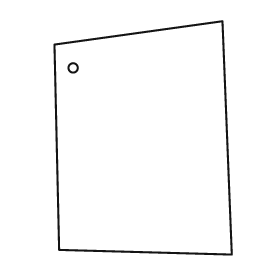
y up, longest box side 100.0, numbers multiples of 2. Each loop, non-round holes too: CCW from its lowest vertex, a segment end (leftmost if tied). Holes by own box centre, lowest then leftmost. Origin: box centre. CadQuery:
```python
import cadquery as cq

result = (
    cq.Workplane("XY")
    .moveTo(38.0, -50.0)
    .lineTo(34.0, 50.0)
    .lineTo(-38.0, 40.0)
    .lineTo(-36.0, -48.0)
    .close()
    .moveTo(-30.0, 30.0)
    .circle(2.0)
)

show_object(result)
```